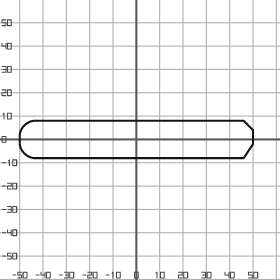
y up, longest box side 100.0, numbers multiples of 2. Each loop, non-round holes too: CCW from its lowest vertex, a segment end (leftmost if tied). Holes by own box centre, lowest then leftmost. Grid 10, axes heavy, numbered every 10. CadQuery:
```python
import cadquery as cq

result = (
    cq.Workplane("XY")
    .moveTo(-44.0, -8.0)
    .lineTo(46.0, -8.0)
    .lineTo(50.0, -2.0)
    .lineTo(50.0, 4.0)
    .lineTo(46.0, 8.0)
    .lineTo(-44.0, 8.0)
    .threePointArc((-48.0, 6.0), (-50.0, 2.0))
    .lineTo(-50.0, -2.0)
    .threePointArc((-48.0, -6.0), (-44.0, -8.0))
    .close()
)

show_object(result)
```